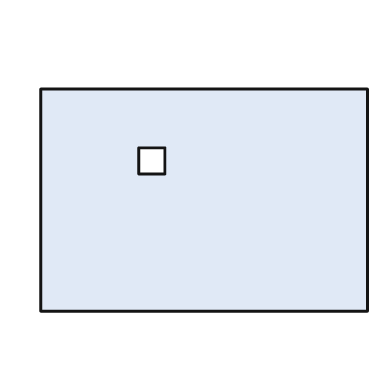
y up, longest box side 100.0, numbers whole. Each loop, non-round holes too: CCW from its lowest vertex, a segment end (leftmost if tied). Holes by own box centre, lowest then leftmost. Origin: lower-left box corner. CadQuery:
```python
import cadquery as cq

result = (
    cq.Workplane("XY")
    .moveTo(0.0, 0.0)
    .lineTo(100.0, 0.0)
    .lineTo(100.0, 68.0)
    .lineTo(0.0, 68.0)
    .close()
    .moveTo(30.0, 42.0)
    .lineTo(38.0, 42.0)
    .lineTo(38.0, 50.0)
    .lineTo(30.0, 50.0)
    .close()
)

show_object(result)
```